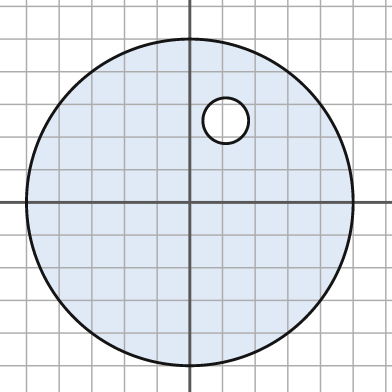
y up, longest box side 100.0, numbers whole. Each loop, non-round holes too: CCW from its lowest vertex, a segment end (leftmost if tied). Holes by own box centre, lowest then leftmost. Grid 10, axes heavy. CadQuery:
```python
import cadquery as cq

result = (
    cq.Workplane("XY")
    .moveTo(0.0, 0.0)
    .circle(50.0)
    .moveTo(11.0, 25.0)
    .circle(7.0)
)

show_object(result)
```